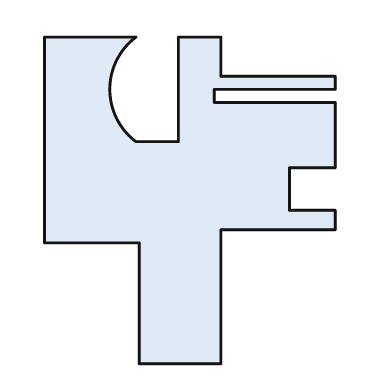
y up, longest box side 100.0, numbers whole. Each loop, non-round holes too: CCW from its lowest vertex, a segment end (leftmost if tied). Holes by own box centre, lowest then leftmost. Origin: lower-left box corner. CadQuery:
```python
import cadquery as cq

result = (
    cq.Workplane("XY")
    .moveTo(29.0, 0.0)
    .lineTo(54.0, 0.0)
    .lineTo(54.0, 41.0)
    .lineTo(89.0, 41.0)
    .lineTo(89.0, 47.0)
    .lineTo(75.0, 47.0)
    .lineTo(75.0, 60.0)
    .lineTo(89.0, 60.0)
    .lineTo(89.0, 80.0)
    .lineTo(52.0, 80.0)
    .lineTo(52.0, 84.0)
    .lineTo(89.0, 84.0)
    .lineTo(89.0, 88.0)
    .lineTo(54.0, 88.0)
    .lineTo(54.0, 100.0)
    .lineTo(41.0, 100.0)
    .lineTo(41.0, 68.0)
    .lineTo(28.0, 68.0)
    .threePointArc((20.0, 84.0), (28.0, 100.0))
    .lineTo(0.0, 100.0)
    .lineTo(0.0, 37.0)
    .lineTo(29.0, 37.0)
    .close()
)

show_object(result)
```